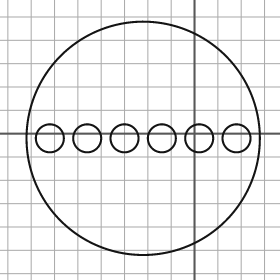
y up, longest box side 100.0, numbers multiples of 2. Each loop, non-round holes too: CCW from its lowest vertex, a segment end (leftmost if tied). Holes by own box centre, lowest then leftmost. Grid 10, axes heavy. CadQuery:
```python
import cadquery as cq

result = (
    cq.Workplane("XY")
    .moveTo(-22.0, -2.0)
    .circle(50.0)
    .moveTo(-62.0, -2.0)
    .circle(6.0)
    .moveTo(-46.0, -2.0)
    .circle(6.0)
    .moveTo(-30.0, -2.0)
    .circle(6.0)
    .moveTo(-14.0, -2.0)
    .circle(6.0)
    .moveTo(2.0, -2.0)
    .circle(6.0)
    .moveTo(18.0, -2.0)
    .circle(6.0)
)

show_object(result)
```